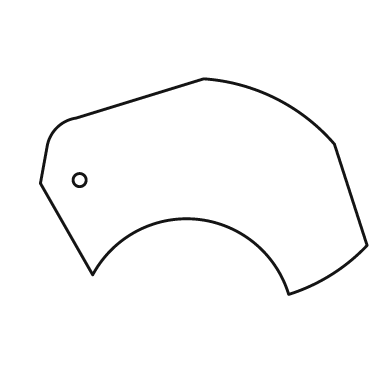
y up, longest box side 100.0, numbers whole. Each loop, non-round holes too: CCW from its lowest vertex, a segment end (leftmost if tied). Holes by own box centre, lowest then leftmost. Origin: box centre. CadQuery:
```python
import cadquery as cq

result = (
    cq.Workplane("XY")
    .moveTo(26.0, -33.0)
    .threePointArc((39.0, -27.0), (50.0, -18.0))
    .lineTo(40.0, 13.0)
    .threePointArc((22.0, 27.0), (0.0, 33.0))
    .lineTo(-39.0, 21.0)
    .threePointArc((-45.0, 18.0), (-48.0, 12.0))
    .lineTo(-50.0, 1.0)
    .lineTo(-34.0, -27.0)
    .threePointArc((-2.0, -10.0), (26.0, -33.0))
    .close()
    .moveTo(-38.0, 2.0)
    .circle(2.0)
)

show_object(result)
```